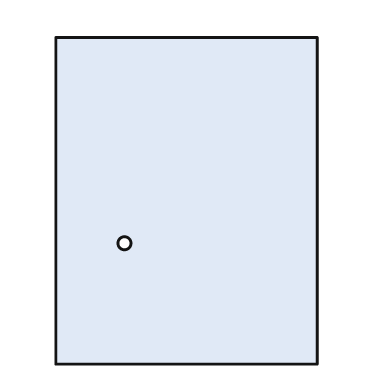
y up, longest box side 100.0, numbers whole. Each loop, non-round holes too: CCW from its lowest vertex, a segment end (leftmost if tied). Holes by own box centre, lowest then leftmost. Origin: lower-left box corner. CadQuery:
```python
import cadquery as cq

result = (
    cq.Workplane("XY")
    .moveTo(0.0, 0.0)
    .lineTo(80.0, 0.0)
    .lineTo(80.0, 100.0)
    .lineTo(0.0, 100.0)
    .close()
    .moveTo(21.0, 37.0)
    .circle(2.0)
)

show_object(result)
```